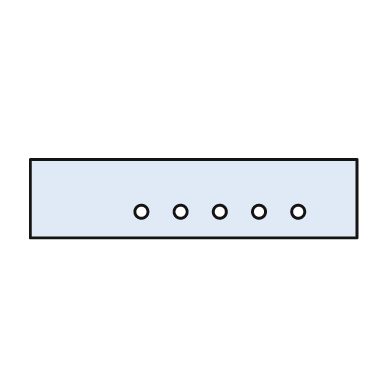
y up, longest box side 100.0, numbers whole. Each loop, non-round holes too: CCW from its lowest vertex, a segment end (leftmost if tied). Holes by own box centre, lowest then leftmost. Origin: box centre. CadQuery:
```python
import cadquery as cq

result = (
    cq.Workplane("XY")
    .moveTo(-50.0, -12.0)
    .lineTo(50.0, -12.0)
    .lineTo(50.0, 12.0)
    .lineTo(-50.0, 12.0)
    .close()
    .moveTo(-16.0, -4.0)
    .circle(2.0)
    .moveTo(-4.0, -4.0)
    .circle(2.0)
    .moveTo(8.0, -4.0)
    .circle(2.0)
    .moveTo(20.0, -4.0)
    .circle(2.0)
    .moveTo(32.0, -4.0)
    .circle(2.0)
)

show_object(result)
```